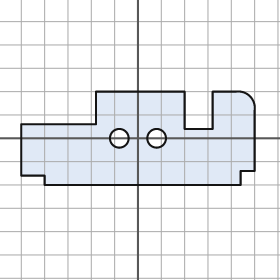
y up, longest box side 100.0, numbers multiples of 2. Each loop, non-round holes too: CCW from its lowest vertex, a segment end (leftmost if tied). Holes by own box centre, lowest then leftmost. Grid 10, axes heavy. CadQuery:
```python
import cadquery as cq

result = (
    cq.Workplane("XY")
    .moveTo(-40.0, -20.0)
    .lineTo(44.0, -20.0)
    .lineTo(44.0, -14.0)
    .lineTo(50.0, -14.0)
    .lineTo(50.0, 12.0)
    .threePointArc((48.0, 18.0), (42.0, 20.0))
    .lineTo(32.0, 20.0)
    .lineTo(32.0, 4.0)
    .lineTo(20.0, 4.0)
    .lineTo(20.0, 20.0)
    .lineTo(-18.0, 20.0)
    .lineTo(-18.0, 6.0)
    .lineTo(-50.0, 6.0)
    .lineTo(-50.0, -16.0)
    .lineTo(-40.0, -16.0)
    .close()
    .moveTo(-8.0, 0.0)
    .circle(4.0)
    .moveTo(8.0, 0.0)
    .circle(4.0)
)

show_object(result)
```